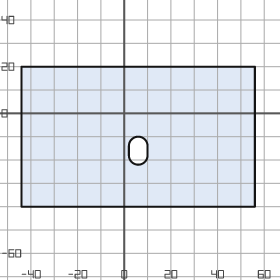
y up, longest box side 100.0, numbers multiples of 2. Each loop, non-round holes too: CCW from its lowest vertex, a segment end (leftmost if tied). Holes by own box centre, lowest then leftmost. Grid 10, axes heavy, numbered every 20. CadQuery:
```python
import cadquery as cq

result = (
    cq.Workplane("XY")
    .moveTo(-44.0, -40.0)
    .lineTo(56.0, -40.0)
    .lineTo(56.0, 20.0)
    .lineTo(-44.0, 20.0)
    .close()
    .moveTo(2.0, -18.0)
    .threePointArc((6.0, -22.0), (10.0, -18.0))
    .lineTo(10.0, -14.0)
    .threePointArc((6.0, -10.0), (2.0, -14.0))
    .close()
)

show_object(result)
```